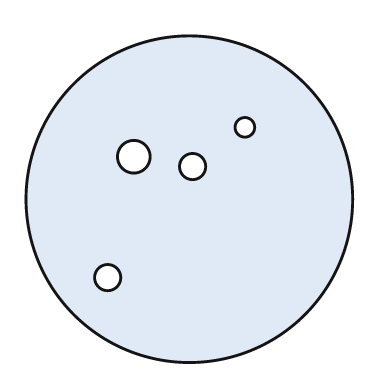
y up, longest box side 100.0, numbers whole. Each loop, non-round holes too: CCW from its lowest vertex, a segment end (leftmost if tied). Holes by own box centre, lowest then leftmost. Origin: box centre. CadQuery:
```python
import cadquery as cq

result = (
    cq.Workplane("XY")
    .moveTo(0.0, 0.0)
    .circle(50.0)
    .moveTo(-25.0, -24.0)
    .circle(4.0)
    .moveTo(1.0, 10.0)
    .circle(4.0)
    .moveTo(-17.0, 13.0)
    .circle(5.0)
    .moveTo(17.0, 22.0)
    .circle(3.0)
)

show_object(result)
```